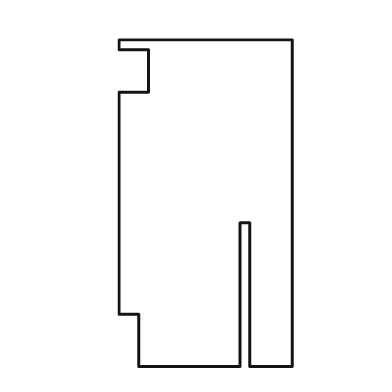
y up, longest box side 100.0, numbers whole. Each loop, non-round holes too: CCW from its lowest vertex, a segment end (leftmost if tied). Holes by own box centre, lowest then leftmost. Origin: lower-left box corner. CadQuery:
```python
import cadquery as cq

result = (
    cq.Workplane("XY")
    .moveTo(6.0, 0.0)
    .lineTo(37.0, 0.0)
    .lineTo(37.0, 44.0)
    .lineTo(40.0, 44.0)
    .lineTo(40.0, 0.0)
    .lineTo(53.0, 0.0)
    .lineTo(53.0, 100.0)
    .lineTo(0.0, 100.0)
    .lineTo(0.0, 97.0)
    .lineTo(9.0, 97.0)
    .lineTo(9.0, 84.0)
    .lineTo(0.0, 84.0)
    .lineTo(0.0, 16.0)
    .lineTo(6.0, 16.0)
    .close()
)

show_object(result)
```